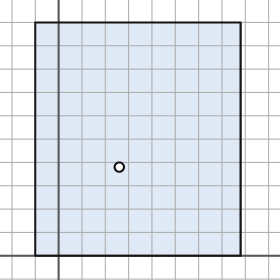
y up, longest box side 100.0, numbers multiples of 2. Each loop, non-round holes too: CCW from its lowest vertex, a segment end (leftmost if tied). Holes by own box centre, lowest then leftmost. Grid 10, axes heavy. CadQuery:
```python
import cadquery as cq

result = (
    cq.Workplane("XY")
    .moveTo(-10.0, 0.0)
    .lineTo(78.0, 0.0)
    .lineTo(78.0, 100.0)
    .lineTo(-10.0, 100.0)
    .close()
    .moveTo(26.0, 38.0)
    .circle(2.0)
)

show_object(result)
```